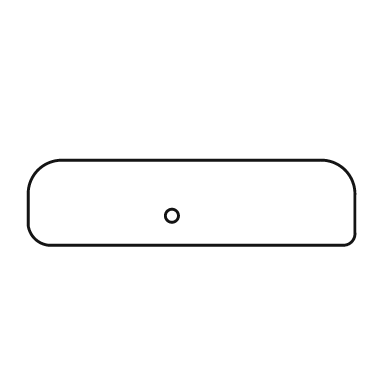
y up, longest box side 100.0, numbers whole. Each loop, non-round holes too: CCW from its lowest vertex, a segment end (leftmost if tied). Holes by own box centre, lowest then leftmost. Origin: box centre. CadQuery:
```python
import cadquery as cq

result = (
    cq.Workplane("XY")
    .moveTo(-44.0, -13.0)
    .lineTo(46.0, -13.0)
    .threePointArc((49.0, -12.0), (50.0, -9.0))
    .lineTo(50.0, 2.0)
    .threePointArc((47.0, 10.0), (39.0, 13.0))
    .lineTo(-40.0, 13.0)
    .threePointArc((-47.0, 10.0), (-50.0, 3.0))
    .lineTo(-50.0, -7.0)
    .threePointArc((-48.0, -11.0), (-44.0, -13.0))
    .close()
    .moveTo(-6.0, -4.0)
    .circle(2.0)
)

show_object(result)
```